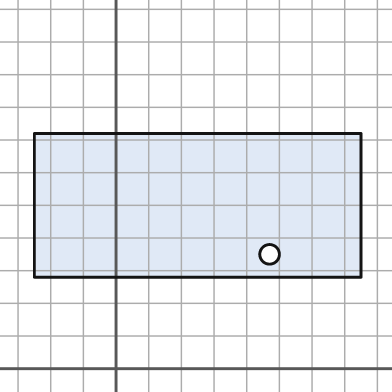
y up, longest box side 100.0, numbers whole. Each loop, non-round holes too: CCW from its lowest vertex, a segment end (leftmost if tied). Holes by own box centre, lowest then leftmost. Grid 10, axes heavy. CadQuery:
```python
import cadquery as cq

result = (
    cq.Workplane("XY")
    .moveTo(-25.0, 28.0)
    .lineTo(75.0, 28.0)
    .lineTo(75.0, 72.0)
    .lineTo(-25.0, 72.0)
    .close()
    .moveTo(47.0, 35.0)
    .circle(3.0)
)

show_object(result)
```